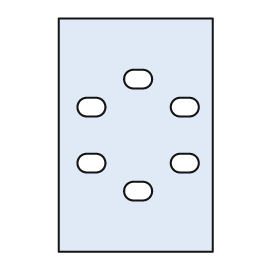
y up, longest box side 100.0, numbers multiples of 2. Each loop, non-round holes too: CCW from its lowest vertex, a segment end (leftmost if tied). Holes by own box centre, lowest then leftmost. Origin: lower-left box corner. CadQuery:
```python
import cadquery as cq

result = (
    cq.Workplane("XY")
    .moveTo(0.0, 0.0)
    .lineTo(66.0, 0.0)
    .lineTo(66.0, 100.0)
    .lineTo(0.0, 100.0)
    .close()
    .moveTo(32.0, 22.0)
    .lineTo(36.0, 22.0)
    .threePointArc((40.0, 26.0), (36.0, 30.0))
    .lineTo(32.0, 30.0)
    .threePointArc((28.0, 26.0), (32.0, 22.0))
    .close()
    .moveTo(12.0, 34.0)
    .lineTo(16.0, 34.0)
    .threePointArc((20.0, 38.0), (16.0, 42.0))
    .lineTo(12.0, 42.0)
    .threePointArc((8.0, 38.0), (12.0, 34.0))
    .close()
    .moveTo(52.0, 34.0)
    .lineTo(56.0, 34.0)
    .threePointArc((60.0, 38.0), (56.0, 42.0))
    .lineTo(52.0, 42.0)
    .threePointArc((48.0, 38.0), (52.0, 34.0))
    .close()
    .moveTo(12.0, 58.0)
    .lineTo(16.0, 58.0)
    .threePointArc((20.0, 62.0), (16.0, 66.0))
    .lineTo(12.0, 66.0)
    .threePointArc((8.0, 62.0), (12.0, 58.0))
    .close()
    .moveTo(52.0, 58.0)
    .lineTo(56.0, 58.0)
    .threePointArc((60.0, 62.0), (56.0, 66.0))
    .lineTo(52.0, 66.0)
    .threePointArc((48.0, 62.0), (52.0, 58.0))
    .close()
    .moveTo(32.0, 70.0)
    .lineTo(36.0, 70.0)
    .threePointArc((40.0, 74.0), (36.0, 78.0))
    .lineTo(32.0, 78.0)
    .threePointArc((28.0, 74.0), (32.0, 70.0))
    .close()
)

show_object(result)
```